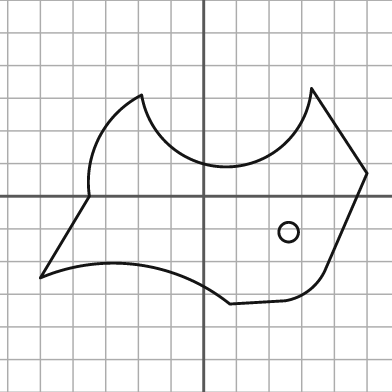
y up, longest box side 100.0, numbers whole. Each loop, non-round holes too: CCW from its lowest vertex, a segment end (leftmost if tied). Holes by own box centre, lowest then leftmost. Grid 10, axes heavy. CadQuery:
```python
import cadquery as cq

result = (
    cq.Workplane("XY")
    .moveTo(8.0, -33.0)
    .lineTo(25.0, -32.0)
    .threePointArc((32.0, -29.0), (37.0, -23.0))
    .lineTo(50.0, 7.0)
    .lineTo(33.0, 33.0)
    .threePointArc((8.0, 9.0), (-19.0, 31.0))
    .threePointArc((-32.0, 18.0), (-35.0, 0.0))
    .lineTo(-50.0, -25.0)
    .threePointArc((-20.0, -21.0), (8.0, -33.0))
    .close()
    .moveTo(26.0, -11.0)
    .circle(3.0)
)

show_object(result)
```